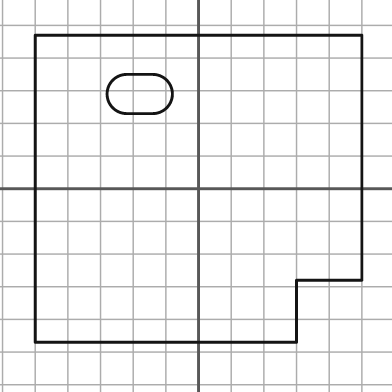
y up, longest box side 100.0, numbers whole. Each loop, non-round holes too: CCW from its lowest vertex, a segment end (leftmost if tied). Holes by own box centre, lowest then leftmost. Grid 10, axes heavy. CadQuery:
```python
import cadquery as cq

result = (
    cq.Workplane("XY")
    .moveTo(-50.0, -47.0)
    .lineTo(30.0, -47.0)
    .lineTo(30.0, -28.0)
    .lineTo(50.0, -28.0)
    .lineTo(50.0, 47.0)
    .lineTo(-50.0, 47.0)
    .close()
    .moveTo(-22.0, 23.0)
    .lineTo(-14.0, 23.0)
    .threePointArc((-8.0, 29.0), (-14.0, 35.0))
    .lineTo(-22.0, 35.0)
    .threePointArc((-28.0, 29.0), (-22.0, 23.0))
    .close()
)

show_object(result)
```